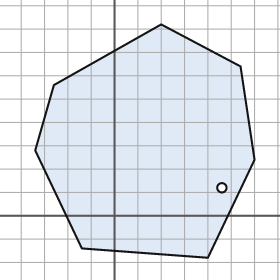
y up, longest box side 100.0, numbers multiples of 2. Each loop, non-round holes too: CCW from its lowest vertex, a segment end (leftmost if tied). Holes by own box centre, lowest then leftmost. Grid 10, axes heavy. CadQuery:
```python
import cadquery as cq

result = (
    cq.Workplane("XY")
    .moveTo(40.0, -18.0)
    .lineTo(60.0, 24.0)
    .lineTo(54.0, 64.0)
    .lineTo(20.0, 82.0)
    .lineTo(-26.0, 56.0)
    .lineTo(-34.0, 28.0)
    .lineTo(-14.0, -14.0)
    .close()
    .moveTo(46.0, 12.0)
    .circle(2.0)
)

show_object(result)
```